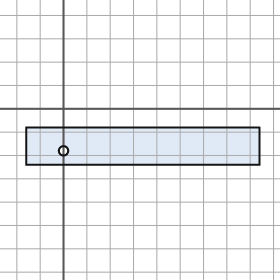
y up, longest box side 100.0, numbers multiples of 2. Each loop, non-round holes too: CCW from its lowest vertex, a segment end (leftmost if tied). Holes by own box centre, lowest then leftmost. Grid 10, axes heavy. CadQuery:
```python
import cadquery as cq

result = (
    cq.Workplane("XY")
    .moveTo(-16.0, -24.0)
    .lineTo(84.0, -24.0)
    .lineTo(84.0, -8.0)
    .lineTo(-16.0, -8.0)
    .close()
    .moveTo(0.0, -18.0)
    .circle(2.0)
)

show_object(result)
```